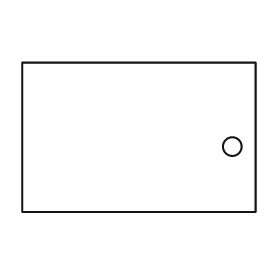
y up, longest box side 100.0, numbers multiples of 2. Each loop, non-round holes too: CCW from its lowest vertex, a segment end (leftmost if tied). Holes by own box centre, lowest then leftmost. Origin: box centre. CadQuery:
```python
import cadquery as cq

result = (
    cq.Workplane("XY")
    .moveTo(-50.0, -32.0)
    .lineTo(50.0, -32.0)
    .lineTo(50.0, 32.0)
    .lineTo(-50.0, 32.0)
    .close()
    .moveTo(40.0, -4.0)
    .circle(4.0)
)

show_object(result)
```